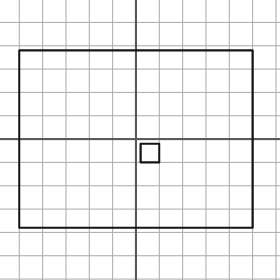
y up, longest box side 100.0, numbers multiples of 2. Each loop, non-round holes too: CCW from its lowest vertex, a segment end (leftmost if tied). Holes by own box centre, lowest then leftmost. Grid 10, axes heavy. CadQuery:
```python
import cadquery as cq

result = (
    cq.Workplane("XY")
    .moveTo(-50.0, -38.0)
    .lineTo(50.0, -38.0)
    .lineTo(50.0, 38.0)
    .lineTo(-50.0, 38.0)
    .close()
    .moveTo(2.0, -10.0)
    .lineTo(10.0, -10.0)
    .lineTo(10.0, -2.0)
    .lineTo(2.0, -2.0)
    .close()
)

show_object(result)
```